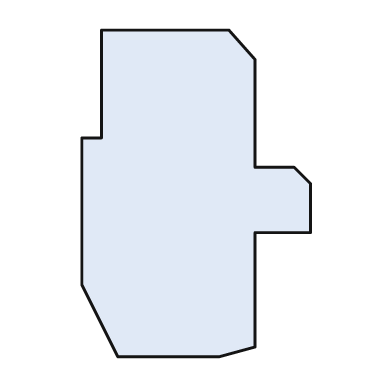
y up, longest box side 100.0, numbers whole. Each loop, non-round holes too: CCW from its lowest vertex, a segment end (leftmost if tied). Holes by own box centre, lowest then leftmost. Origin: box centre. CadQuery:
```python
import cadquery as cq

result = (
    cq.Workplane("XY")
    .moveTo(-24.0, -50.0)
    .lineTo(7.0, -50.0)
    .lineTo(18.0, -47.0)
    .lineTo(18.0, -12.0)
    .lineTo(35.0, -12.0)
    .lineTo(35.0, 3.0)
    .lineTo(30.0, 8.0)
    .lineTo(18.0, 8.0)
    .lineTo(18.0, 41.0)
    .lineTo(10.0, 50.0)
    .lineTo(-29.0, 50.0)
    .lineTo(-29.0, 17.0)
    .lineTo(-35.0, 17.0)
    .lineTo(-35.0, -28.0)
    .close()
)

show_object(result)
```